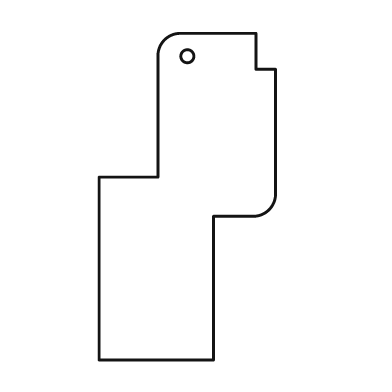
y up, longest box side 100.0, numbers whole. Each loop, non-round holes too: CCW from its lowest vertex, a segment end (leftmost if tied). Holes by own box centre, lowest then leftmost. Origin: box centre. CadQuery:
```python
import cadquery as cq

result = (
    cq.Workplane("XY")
    .moveTo(-27.0, -50.0)
    .lineTo(8.0, -50.0)
    .lineTo(8.0, -6.0)
    .lineTo(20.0, -6.0)
    .threePointArc((25.0, -4.0), (27.0, 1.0))
    .lineTo(27.0, 39.0)
    .lineTo(21.0, 39.0)
    .lineTo(21.0, 50.0)
    .lineTo(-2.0, 50.0)
    .threePointArc((-7.0, 48.0), (-9.0, 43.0))
    .lineTo(-9.0, 6.0)
    .lineTo(-27.0, 6.0)
    .close()
    .moveTo(0.0, 43.0)
    .circle(2.0)
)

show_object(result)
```